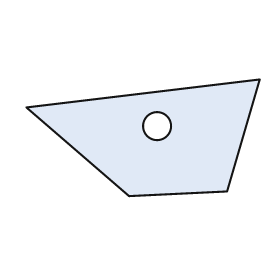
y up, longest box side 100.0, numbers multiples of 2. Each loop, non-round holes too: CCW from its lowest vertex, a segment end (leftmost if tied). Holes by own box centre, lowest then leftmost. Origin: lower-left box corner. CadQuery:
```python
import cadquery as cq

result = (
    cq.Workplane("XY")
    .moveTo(44.0, 0.0)
    .lineTo(86.0, 2.0)
    .lineTo(100.0, 50.0)
    .lineTo(0.0, 38.0)
    .close()
    .moveTo(56.0, 30.0)
    .circle(6.0)
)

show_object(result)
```